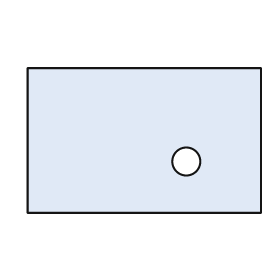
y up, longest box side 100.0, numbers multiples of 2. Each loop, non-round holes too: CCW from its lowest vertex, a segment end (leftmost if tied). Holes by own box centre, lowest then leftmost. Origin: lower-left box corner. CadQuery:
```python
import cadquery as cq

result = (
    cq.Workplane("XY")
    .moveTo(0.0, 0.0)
    .lineTo(100.0, 0.0)
    .lineTo(100.0, 62.0)
    .lineTo(0.0, 62.0)
    .close()
    .moveTo(68.0, 22.0)
    .circle(6.0)
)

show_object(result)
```